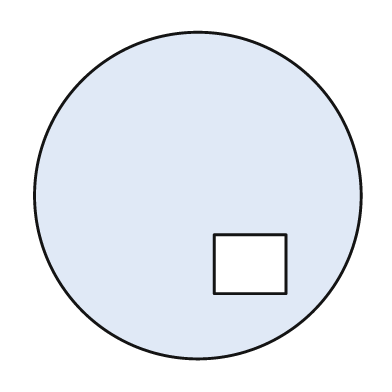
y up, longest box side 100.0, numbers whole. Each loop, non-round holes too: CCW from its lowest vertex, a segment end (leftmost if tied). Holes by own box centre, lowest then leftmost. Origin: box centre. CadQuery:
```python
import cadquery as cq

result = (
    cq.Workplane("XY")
    .moveTo(0.0, 0.0)
    .circle(50.0)
    .moveTo(5.0, -30.0)
    .lineTo(27.0, -30.0)
    .lineTo(27.0, -12.0)
    .lineTo(5.0, -12.0)
    .close()
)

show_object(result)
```